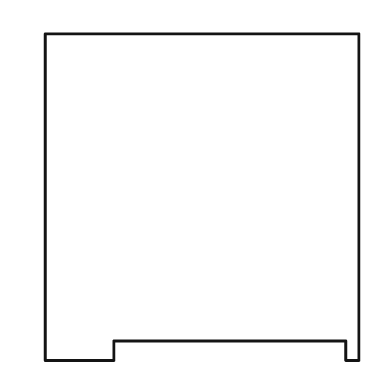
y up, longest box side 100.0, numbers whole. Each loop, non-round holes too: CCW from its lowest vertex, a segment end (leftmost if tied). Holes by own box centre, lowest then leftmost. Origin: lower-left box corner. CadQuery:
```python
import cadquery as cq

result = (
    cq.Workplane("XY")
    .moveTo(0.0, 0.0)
    .lineTo(21.0, 0.0)
    .lineTo(21.0, 6.0)
    .lineTo(92.0, 6.0)
    .lineTo(92.0, 0.0)
    .lineTo(96.0, 0.0)
    .lineTo(96.0, 100.0)
    .lineTo(0.0, 100.0)
    .close()
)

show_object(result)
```